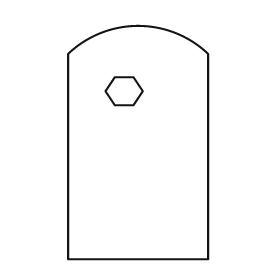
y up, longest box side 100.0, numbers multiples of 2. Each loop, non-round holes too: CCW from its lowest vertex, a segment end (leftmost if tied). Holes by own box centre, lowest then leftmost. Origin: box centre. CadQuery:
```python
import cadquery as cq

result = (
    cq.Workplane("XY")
    .moveTo(-30.0, -50.0)
    .lineTo(30.0, -50.0)
    .lineTo(30.0, 38.0)
    .threePointArc((0.0, 50.0), (-30.0, 38.0))
    .close()
    .moveTo(-10.0, 16.0)
    .lineTo(-2.0, 16.0)
    .lineTo(2.0, 22.0)
    .lineTo(-2.0, 28.0)
    .lineTo(-10.0, 28.0)
    .lineTo(-14.0, 22.0)
    .close()
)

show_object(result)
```